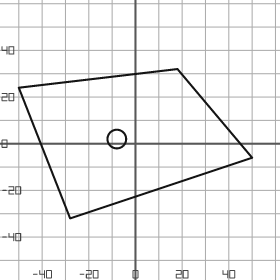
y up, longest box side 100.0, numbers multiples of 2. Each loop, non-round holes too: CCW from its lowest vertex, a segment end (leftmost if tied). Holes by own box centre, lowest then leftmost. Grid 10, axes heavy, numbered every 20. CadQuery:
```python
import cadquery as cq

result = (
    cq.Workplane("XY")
    .moveTo(-28.0, -32.0)
    .lineTo(50.0, -6.0)
    .lineTo(18.0, 32.0)
    .lineTo(-50.0, 24.0)
    .close()
    .moveTo(-8.0, 2.0)
    .circle(4.0)
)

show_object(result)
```